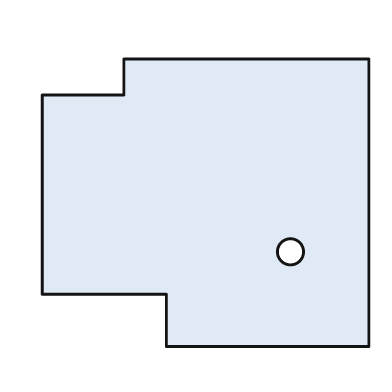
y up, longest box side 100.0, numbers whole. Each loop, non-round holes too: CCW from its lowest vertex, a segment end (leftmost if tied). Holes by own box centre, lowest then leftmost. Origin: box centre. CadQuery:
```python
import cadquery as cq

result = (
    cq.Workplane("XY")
    .moveTo(-12.0, -44.0)
    .lineTo(50.0, -44.0)
    .lineTo(50.0, 44.0)
    .lineTo(-25.0, 44.0)
    .lineTo(-25.0, 33.0)
    .lineTo(-50.0, 33.0)
    .lineTo(-50.0, -28.0)
    .lineTo(-12.0, -28.0)
    .close()
    .moveTo(26.0, -15.0)
    .circle(4.0)
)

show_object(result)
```